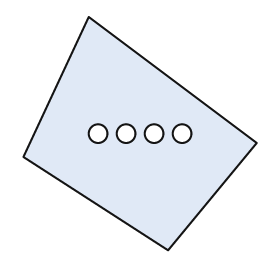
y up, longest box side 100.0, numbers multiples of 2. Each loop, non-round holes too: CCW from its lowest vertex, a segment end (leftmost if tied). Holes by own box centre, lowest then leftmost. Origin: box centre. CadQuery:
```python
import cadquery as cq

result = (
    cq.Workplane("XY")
    .moveTo(12.0, -50.0)
    .lineTo(50.0, -4.0)
    .lineTo(-22.0, 50.0)
    .lineTo(-50.0, -10.0)
    .close()
    .moveTo(-18.0, 0.0)
    .circle(4.0)
    .moveTo(-6.0, 0.0)
    .circle(4.0)
    .moveTo(6.0, 0.0)
    .circle(4.0)
    .moveTo(18.0, 0.0)
    .circle(4.0)
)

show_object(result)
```